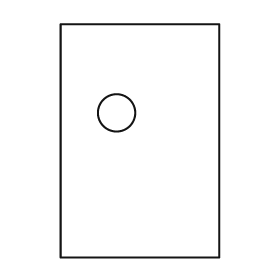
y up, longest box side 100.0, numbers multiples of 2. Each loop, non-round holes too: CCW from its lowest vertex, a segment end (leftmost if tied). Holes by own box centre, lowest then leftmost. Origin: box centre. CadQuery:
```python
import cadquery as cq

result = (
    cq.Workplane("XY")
    .moveTo(-34.0, -50.0)
    .lineTo(34.0, -50.0)
    .lineTo(34.0, 50.0)
    .lineTo(-34.0, 50.0)
    .close()
    .moveTo(-10.0, 12.0)
    .circle(8.0)
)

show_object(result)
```